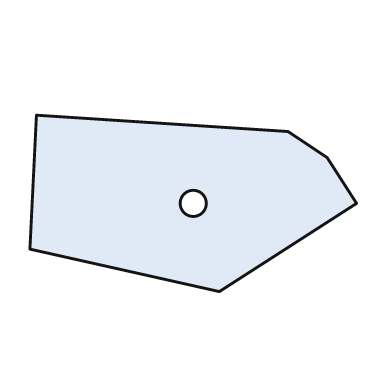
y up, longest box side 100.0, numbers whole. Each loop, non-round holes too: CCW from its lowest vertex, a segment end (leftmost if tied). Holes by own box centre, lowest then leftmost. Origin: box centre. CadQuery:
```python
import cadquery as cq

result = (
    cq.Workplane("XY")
    .moveTo(8.0, -27.0)
    .lineTo(50.0, 0.0)
    .lineTo(41.0, 14.0)
    .lineTo(29.0, 22.0)
    .lineTo(-48.0, 27.0)
    .lineTo(-50.0, -14.0)
    .close()
    .moveTo(0.0, 0.0)
    .circle(4.0)
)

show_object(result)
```